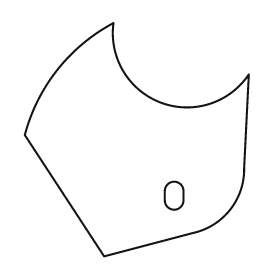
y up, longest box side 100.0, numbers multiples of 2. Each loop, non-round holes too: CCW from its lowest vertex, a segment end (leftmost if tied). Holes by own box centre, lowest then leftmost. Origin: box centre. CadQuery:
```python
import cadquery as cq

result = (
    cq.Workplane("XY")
    .moveTo(-14.0, -50.0)
    .lineTo(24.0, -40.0)
    .threePointArc((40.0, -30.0), (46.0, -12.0))
    .lineTo(48.0, 28.0)
    .threePointArc((10.0, 16.0), (-10.0, 50.0))
    .threePointArc((-34.0, 30.0), (-48.0, 2.0))
    .close()
    .moveTo(12.0, -26.0)
    .threePointArc((16.0, -30.0), (20.0, -26.0))
    .lineTo(20.0, -22.0)
    .threePointArc((16.0, -18.0), (12.0, -22.0))
    .close()
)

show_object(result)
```